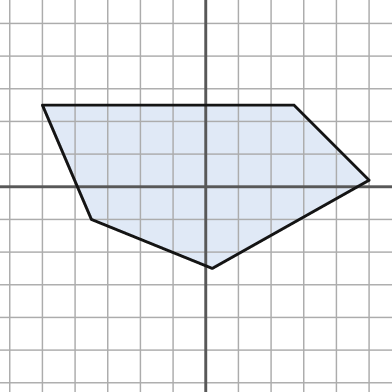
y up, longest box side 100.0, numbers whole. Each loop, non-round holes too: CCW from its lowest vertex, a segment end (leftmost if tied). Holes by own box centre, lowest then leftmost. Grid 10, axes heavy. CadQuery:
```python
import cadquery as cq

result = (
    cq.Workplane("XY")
    .moveTo(2.0, -25.0)
    .lineTo(50.0, 2.0)
    .lineTo(27.0, 25.0)
    .lineTo(-50.0, 25.0)
    .lineTo(-35.0, -10.0)
    .close()
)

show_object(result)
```